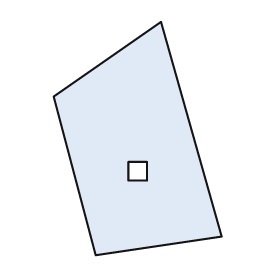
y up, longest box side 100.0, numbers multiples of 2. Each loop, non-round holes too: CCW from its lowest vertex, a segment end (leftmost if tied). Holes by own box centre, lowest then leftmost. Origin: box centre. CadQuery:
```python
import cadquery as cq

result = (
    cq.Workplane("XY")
    .moveTo(-18.0, -50.0)
    .lineTo(36.0, -42.0)
    .lineTo(10.0, 50.0)
    .lineTo(-36.0, 18.0)
    .close()
    .moveTo(-4.0, -18.0)
    .lineTo(4.0, -18.0)
    .lineTo(4.0, -10.0)
    .lineTo(-4.0, -10.0)
    .close()
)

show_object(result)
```